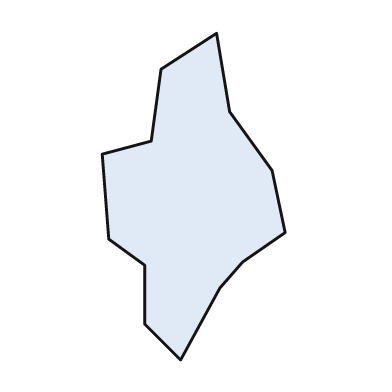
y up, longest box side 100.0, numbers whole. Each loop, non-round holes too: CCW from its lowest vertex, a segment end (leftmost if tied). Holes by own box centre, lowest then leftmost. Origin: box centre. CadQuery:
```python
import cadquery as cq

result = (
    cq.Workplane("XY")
    .moveTo(-4.0, -50.0)
    .lineTo(8.0, -28.0)
    .lineTo(15.0, -20.0)
    .lineTo(28.0, -11.0)
    .lineTo(24.0, 8.0)
    .lineTo(11.0, 26.0)
    .lineTo(7.0, 50.0)
    .lineTo(-10.0, 39.0)
    .lineTo(-13.0, 17.0)
    .lineTo(-28.0, 13.0)
    .lineTo(-26.0, -13.0)
    .lineTo(-15.0, -21.0)
    .lineTo(-15.0, -39.0)
    .close()
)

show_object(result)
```